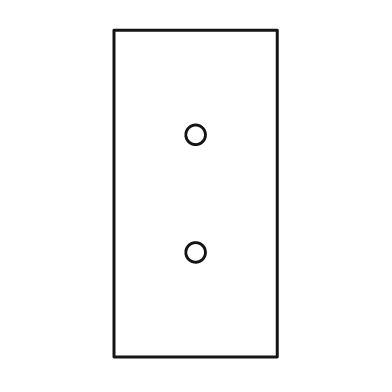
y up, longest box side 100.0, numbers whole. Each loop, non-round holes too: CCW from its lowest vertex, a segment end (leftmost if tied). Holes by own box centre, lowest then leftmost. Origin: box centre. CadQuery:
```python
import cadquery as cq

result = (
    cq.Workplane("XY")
    .moveTo(-25.0, -50.0)
    .lineTo(25.0, -50.0)
    .lineTo(25.0, 50.0)
    .lineTo(-25.0, 50.0)
    .close()
    .moveTo(0.0, -18.0)
    .circle(3.0)
    .moveTo(0.0, 18.0)
    .circle(3.0)
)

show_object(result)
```